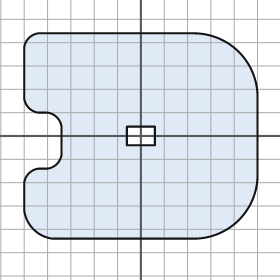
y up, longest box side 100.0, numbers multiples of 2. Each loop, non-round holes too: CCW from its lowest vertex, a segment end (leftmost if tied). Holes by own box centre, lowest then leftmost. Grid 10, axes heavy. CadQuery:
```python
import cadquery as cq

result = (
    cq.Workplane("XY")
    .moveTo(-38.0, -44.0)
    .lineTo(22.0, -44.0)
    .threePointArc((42.0, -36.0), (50.0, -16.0))
    .lineTo(50.0, 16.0)
    .threePointArc((42.0, 36.0), (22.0, 44.0))
    .lineTo(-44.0, 44.0)
    .threePointArc((-48.0, 42.0), (-50.0, 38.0))
    .lineTo(-50.0, 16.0)
    .threePointArc((-48.0, 12.0), (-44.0, 10.0))
    .lineTo(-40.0, 10.0)
    .threePointArc((-36.0, 8.0), (-34.0, 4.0))
    .lineTo(-34.0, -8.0)
    .threePointArc((-36.0, -12.0), (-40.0, -14.0))
    .lineTo(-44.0, -14.0)
    .threePointArc((-48.0, -16.0), (-50.0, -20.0))
    .lineTo(-50.0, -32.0)
    .threePointArc((-46.0, -40.0), (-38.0, -44.0))
    .close()
    .moveTo(-6.0, -4.0)
    .lineTo(6.0, -4.0)
    .lineTo(6.0, 4.0)
    .lineTo(-6.0, 4.0)
    .close()
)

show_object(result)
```